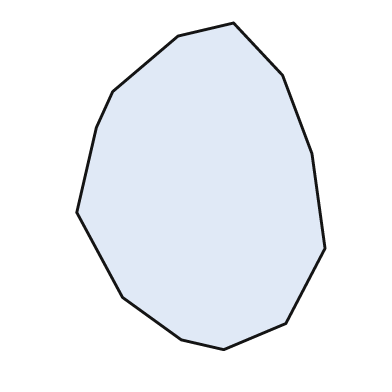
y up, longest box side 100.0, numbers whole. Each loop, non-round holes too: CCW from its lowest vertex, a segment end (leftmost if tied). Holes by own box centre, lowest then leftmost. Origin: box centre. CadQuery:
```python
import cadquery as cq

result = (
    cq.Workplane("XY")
    .moveTo(7.0, -50.0)
    .lineTo(26.0, -42.0)
    .lineTo(38.0, -19.0)
    .lineTo(34.0, 10.0)
    .lineTo(25.0, 34.0)
    .lineTo(10.0, 50.0)
    .lineTo(-7.0, 46.0)
    .lineTo(-27.0, 29.0)
    .lineTo(-32.0, 18.0)
    .lineTo(-38.0, -8.0)
    .lineTo(-24.0, -34.0)
    .lineTo(-6.0, -47.0)
    .close()
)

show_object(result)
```